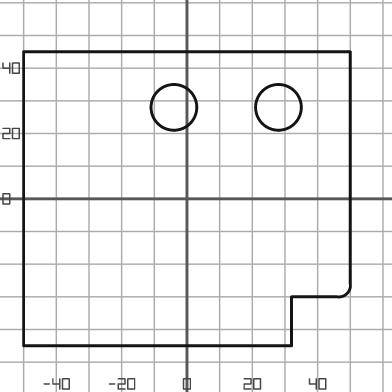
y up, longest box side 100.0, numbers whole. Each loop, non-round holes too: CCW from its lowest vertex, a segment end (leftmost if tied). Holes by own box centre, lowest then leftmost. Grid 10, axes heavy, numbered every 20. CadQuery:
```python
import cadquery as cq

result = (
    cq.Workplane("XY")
    .moveTo(-50.0, -45.0)
    .lineTo(32.0, -45.0)
    .lineTo(32.0, -30.0)
    .lineTo(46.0, -30.0)
    .threePointArc((49.0, -29.0), (50.0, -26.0))
    .lineTo(50.0, 45.0)
    .lineTo(-50.0, 45.0)
    .close()
    .moveTo(-4.0, 28.0)
    .circle(7.0)
    .moveTo(28.0, 28.0)
    .circle(7.0)
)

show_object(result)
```